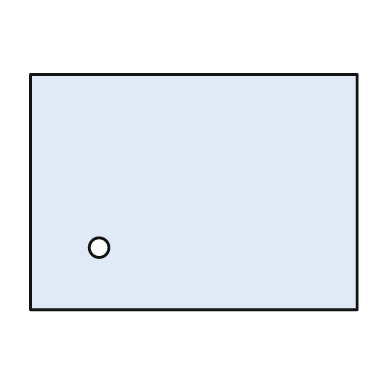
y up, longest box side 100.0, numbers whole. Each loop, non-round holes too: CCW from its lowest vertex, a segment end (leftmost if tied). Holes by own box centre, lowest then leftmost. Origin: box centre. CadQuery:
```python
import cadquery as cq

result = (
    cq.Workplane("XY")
    .moveTo(-50.0, -36.0)
    .lineTo(50.0, -36.0)
    .lineTo(50.0, 36.0)
    .lineTo(-50.0, 36.0)
    .close()
    .moveTo(-29.0, -17.0)
    .circle(3.0)
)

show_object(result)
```